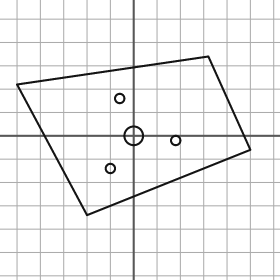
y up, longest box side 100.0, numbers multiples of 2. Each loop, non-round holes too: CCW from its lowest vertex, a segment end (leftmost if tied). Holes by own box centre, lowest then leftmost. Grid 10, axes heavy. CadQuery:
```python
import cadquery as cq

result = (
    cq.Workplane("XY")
    .moveTo(-20.0, -34.0)
    .lineTo(50.0, -6.0)
    .lineTo(32.0, 34.0)
    .lineTo(-50.0, 22.0)
    .close()
    .moveTo(-10.0, -14.0)
    .circle(2.0)
    .moveTo(18.0, -2.0)
    .circle(2.0)
    .moveTo(0.0, 0.0)
    .circle(4.0)
    .moveTo(-6.0, 16.0)
    .circle(2.0)
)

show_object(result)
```